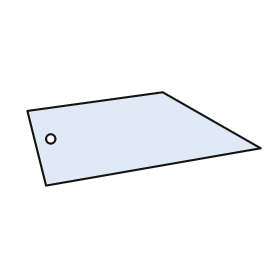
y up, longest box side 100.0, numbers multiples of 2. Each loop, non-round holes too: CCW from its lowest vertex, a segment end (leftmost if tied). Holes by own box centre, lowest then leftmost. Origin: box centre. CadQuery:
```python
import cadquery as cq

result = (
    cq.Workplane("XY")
    .moveTo(-42.0, -20.0)
    .lineTo(50.0, -4.0)
    .lineTo(8.0, 20.0)
    .lineTo(-50.0, 12.0)
    .close()
    .moveTo(-40.0, 0.0)
    .circle(2.0)
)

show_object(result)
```